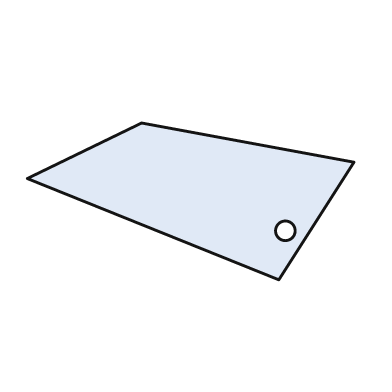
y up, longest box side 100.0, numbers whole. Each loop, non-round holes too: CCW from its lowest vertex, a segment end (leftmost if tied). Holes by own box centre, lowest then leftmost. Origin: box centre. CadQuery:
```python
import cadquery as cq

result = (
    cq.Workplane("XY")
    .moveTo(27.0, -24.0)
    .lineTo(50.0, 12.0)
    .lineTo(-15.0, 24.0)
    .lineTo(-50.0, 7.0)
    .close()
    .moveTo(29.0, -9.0)
    .circle(3.0)
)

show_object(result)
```